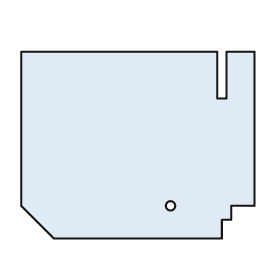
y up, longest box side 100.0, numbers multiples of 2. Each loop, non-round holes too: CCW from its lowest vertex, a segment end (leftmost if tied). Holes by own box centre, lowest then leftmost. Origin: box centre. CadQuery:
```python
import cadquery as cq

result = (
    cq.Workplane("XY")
    .moveTo(-36.0, -40.0)
    .lineTo(36.0, -40.0)
    .lineTo(36.0, -32.0)
    .lineTo(40.0, -32.0)
    .lineTo(40.0, -26.0)
    .lineTo(50.0, -26.0)
    .lineTo(50.0, 40.0)
    .lineTo(38.0, 40.0)
    .lineTo(38.0, 20.0)
    .lineTo(34.0, 20.0)
    .lineTo(34.0, 40.0)
    .lineTo(-50.0, 40.0)
    .lineTo(-50.0, -26.0)
    .close()
    .moveTo(14.0, -26.0)
    .circle(2.0)
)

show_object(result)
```